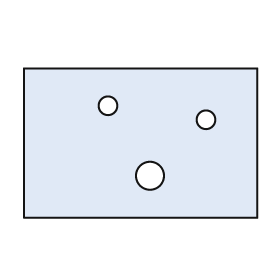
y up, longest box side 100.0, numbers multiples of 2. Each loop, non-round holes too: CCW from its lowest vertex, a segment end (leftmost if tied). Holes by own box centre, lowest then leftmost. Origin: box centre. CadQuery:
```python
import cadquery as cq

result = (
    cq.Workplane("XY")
    .moveTo(-50.0, -32.0)
    .lineTo(50.0, -32.0)
    .lineTo(50.0, 32.0)
    .lineTo(-50.0, 32.0)
    .close()
    .moveTo(4.0, -14.0)
    .circle(6.0)
    .moveTo(28.0, 10.0)
    .circle(4.0)
    .moveTo(-14.0, 16.0)
    .circle(4.0)
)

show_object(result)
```